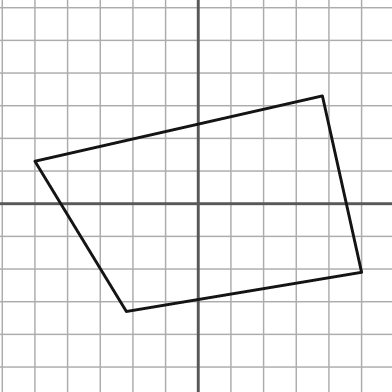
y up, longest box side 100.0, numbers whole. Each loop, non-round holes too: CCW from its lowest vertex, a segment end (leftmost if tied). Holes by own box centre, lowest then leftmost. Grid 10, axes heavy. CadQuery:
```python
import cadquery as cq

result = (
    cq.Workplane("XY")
    .moveTo(-22.0, -33.0)
    .lineTo(50.0, -21.0)
    .lineTo(38.0, 33.0)
    .lineTo(-50.0, 13.0)
    .close()
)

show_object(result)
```